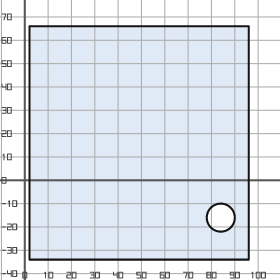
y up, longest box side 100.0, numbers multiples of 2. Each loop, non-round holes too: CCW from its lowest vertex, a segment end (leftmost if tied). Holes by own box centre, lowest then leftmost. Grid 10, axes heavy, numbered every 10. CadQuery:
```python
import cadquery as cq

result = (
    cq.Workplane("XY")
    .moveTo(2.0, -34.0)
    .lineTo(96.0, -34.0)
    .lineTo(96.0, 66.0)
    .lineTo(2.0, 66.0)
    .close()
    .moveTo(84.0, -16.0)
    .circle(6.0)
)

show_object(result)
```